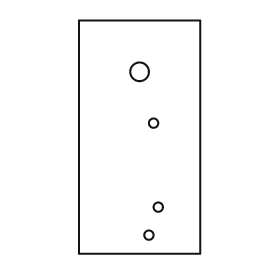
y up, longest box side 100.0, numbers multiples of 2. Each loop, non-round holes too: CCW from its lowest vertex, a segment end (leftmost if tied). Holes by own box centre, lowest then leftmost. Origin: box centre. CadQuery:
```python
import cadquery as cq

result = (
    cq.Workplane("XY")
    .moveTo(-26.0, -50.0)
    .lineTo(26.0, -50.0)
    .lineTo(26.0, 50.0)
    .lineTo(-26.0, 50.0)
    .close()
    .moveTo(4.0, -42.0)
    .circle(2.0)
    .moveTo(8.0, -30.0)
    .circle(2.0)
    .moveTo(6.0, 6.0)
    .circle(2.0)
    .moveTo(0.0, 28.0)
    .circle(4.0)
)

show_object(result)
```